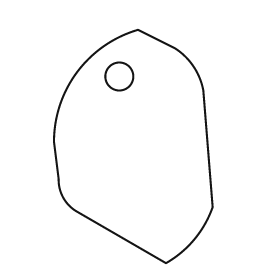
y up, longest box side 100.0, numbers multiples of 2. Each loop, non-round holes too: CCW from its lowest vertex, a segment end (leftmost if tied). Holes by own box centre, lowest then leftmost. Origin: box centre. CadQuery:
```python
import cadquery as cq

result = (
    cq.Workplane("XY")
    .moveTo(14.0, -50.0)
    .threePointArc((26.0, -40.0), (34.0, -26.0))
    .lineTo(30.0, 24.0)
    .threePointArc((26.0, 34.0), (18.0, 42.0))
    .lineTo(2.0, 50.0)
    .threePointArc((-24.0, 32.0), (-34.0, 2.0))
    .lineTo(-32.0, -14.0)
    .threePointArc((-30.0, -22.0), (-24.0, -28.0))
    .close()
    .moveTo(-6.0, 30.0)
    .circle(6.0)
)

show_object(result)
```